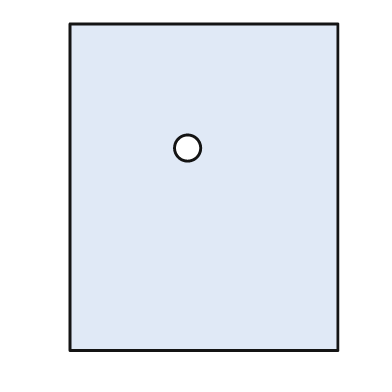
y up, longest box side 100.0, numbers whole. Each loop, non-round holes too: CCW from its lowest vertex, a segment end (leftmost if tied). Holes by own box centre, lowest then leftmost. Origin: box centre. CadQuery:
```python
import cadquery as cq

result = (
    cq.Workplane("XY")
    .moveTo(-41.0, -50.0)
    .lineTo(41.0, -50.0)
    .lineTo(41.0, 50.0)
    .lineTo(-41.0, 50.0)
    .close()
    .moveTo(-5.0, 12.0)
    .circle(4.0)
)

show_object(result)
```